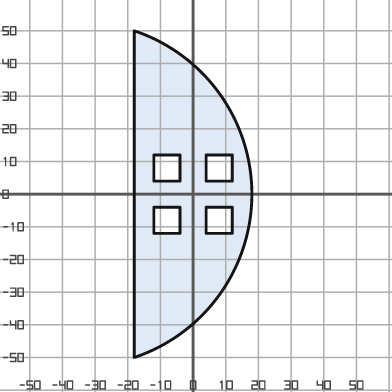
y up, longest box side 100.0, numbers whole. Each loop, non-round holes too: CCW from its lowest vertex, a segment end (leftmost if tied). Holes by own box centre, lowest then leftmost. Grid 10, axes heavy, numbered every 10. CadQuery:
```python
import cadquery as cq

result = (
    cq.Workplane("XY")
    .moveTo(-18.0, -50.0)
    .threePointArc((18.0, 0.0), (-18.0, 50.0))
    .close()
    .moveTo(-12.0, -12.0)
    .lineTo(-4.0, -12.0)
    .lineTo(-4.0, -4.0)
    .lineTo(-12.0, -4.0)
    .close()
    .moveTo(4.0, -12.0)
    .lineTo(12.0, -12.0)
    .lineTo(12.0, -4.0)
    .lineTo(4.0, -4.0)
    .close()
    .moveTo(-12.0, 4.0)
    .lineTo(-4.0, 4.0)
    .lineTo(-4.0, 12.0)
    .lineTo(-12.0, 12.0)
    .close()
    .moveTo(4.0, 4.0)
    .lineTo(12.0, 4.0)
    .lineTo(12.0, 12.0)
    .lineTo(4.0, 12.0)
    .close()
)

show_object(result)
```